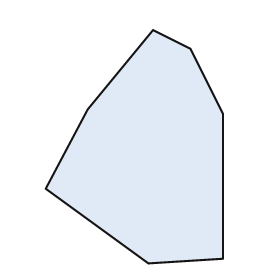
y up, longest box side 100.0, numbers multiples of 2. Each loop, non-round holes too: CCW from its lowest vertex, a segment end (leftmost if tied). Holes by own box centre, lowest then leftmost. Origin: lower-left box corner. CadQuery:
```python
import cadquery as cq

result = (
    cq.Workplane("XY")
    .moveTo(44.0, 0.0)
    .lineTo(76.0, 2.0)
    .lineTo(76.0, 64.0)
    .lineTo(62.0, 92.0)
    .lineTo(46.0, 100.0)
    .lineTo(18.0, 66.0)
    .lineTo(0.0, 32.0)
    .close()
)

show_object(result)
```